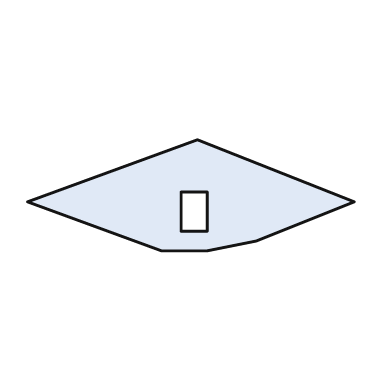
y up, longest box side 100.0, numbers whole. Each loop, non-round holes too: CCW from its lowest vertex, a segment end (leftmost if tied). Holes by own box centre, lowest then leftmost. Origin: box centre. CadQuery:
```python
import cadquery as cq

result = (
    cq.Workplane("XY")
    .moveTo(-9.0, -17.0)
    .lineTo(5.0, -17.0)
    .lineTo(20.0, -14.0)
    .lineTo(50.0, -2.0)
    .lineTo(2.0, 17.0)
    .lineTo(-50.0, -2.0)
    .close()
    .moveTo(-3.0, -11.0)
    .lineTo(5.0, -11.0)
    .lineTo(5.0, 1.0)
    .lineTo(-3.0, 1.0)
    .close()
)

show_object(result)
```